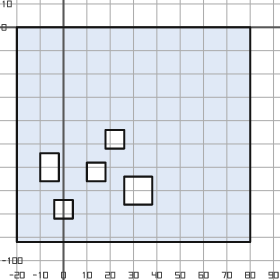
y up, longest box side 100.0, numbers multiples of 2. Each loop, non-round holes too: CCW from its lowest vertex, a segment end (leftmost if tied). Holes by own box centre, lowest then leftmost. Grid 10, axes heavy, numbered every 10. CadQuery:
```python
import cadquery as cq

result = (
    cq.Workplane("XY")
    .moveTo(-20.0, -92.0)
    .lineTo(80.0, -92.0)
    .lineTo(80.0, 0.0)
    .lineTo(-20.0, 0.0)
    .close()
    .moveTo(-4.0, -82.0)
    .lineTo(4.0, -82.0)
    .lineTo(4.0, -74.0)
    .lineTo(-4.0, -74.0)
    .close()
    .moveTo(26.0, -76.0)
    .lineTo(38.0, -76.0)
    .lineTo(38.0, -64.0)
    .lineTo(26.0, -64.0)
    .close()
    .moveTo(10.0, -66.0)
    .lineTo(18.0, -66.0)
    .lineTo(18.0, -58.0)
    .lineTo(10.0, -58.0)
    .close()
    .moveTo(-10.0, -66.0)
    .lineTo(-2.0, -66.0)
    .lineTo(-2.0, -54.0)
    .lineTo(-10.0, -54.0)
    .close()
    .moveTo(18.0, -52.0)
    .lineTo(26.0, -52.0)
    .lineTo(26.0, -44.0)
    .lineTo(18.0, -44.0)
    .close()
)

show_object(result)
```